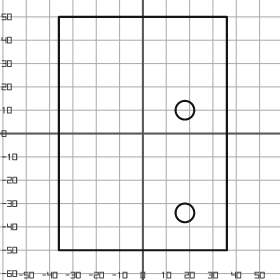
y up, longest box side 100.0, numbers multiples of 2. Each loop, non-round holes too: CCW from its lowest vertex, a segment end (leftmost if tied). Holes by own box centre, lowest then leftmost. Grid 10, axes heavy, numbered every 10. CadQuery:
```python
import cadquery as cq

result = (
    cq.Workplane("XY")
    .moveTo(-36.0, -50.0)
    .lineTo(36.0, -50.0)
    .lineTo(36.0, 50.0)
    .lineTo(-36.0, 50.0)
    .close()
    .moveTo(18.0, -34.0)
    .circle(4.0)
    .moveTo(18.0, 10.0)
    .circle(4.0)
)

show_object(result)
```